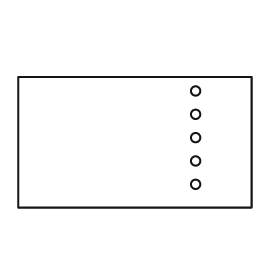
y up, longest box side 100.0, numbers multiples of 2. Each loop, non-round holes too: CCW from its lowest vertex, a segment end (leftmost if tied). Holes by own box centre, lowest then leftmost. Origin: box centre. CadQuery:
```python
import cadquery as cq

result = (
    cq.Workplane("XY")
    .moveTo(-50.0, -28.0)
    .lineTo(50.0, -28.0)
    .lineTo(50.0, 28.0)
    .lineTo(-50.0, 28.0)
    .close()
    .moveTo(26.0, -18.0)
    .circle(2.0)
    .moveTo(26.0, -8.0)
    .circle(2.0)
    .moveTo(26.0, 2.0)
    .circle(2.0)
    .moveTo(26.0, 12.0)
    .circle(2.0)
    .moveTo(26.0, 22.0)
    .circle(2.0)
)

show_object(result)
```